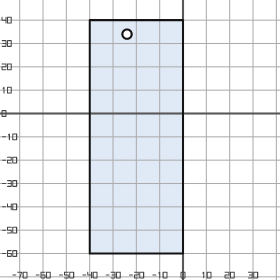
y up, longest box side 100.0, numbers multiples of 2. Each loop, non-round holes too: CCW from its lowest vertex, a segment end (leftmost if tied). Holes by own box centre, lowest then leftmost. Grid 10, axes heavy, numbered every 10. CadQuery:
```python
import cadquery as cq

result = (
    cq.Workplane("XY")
    .moveTo(-40.0, -60.0)
    .lineTo(0.0, -60.0)
    .lineTo(0.0, 40.0)
    .lineTo(-40.0, 40.0)
    .close()
    .moveTo(-24.0, 34.0)
    .circle(2.0)
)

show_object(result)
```